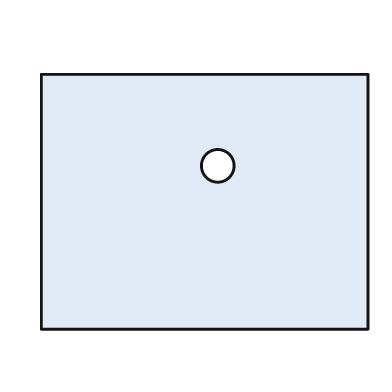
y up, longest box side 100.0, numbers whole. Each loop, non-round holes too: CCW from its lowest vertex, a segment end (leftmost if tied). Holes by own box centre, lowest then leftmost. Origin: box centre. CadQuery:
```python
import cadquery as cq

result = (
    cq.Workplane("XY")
    .moveTo(-50.0, -39.0)
    .lineTo(50.0, -39.0)
    .lineTo(50.0, 39.0)
    .lineTo(-50.0, 39.0)
    .close()
    .moveTo(4.0, 11.0)
    .circle(5.0)
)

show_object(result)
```